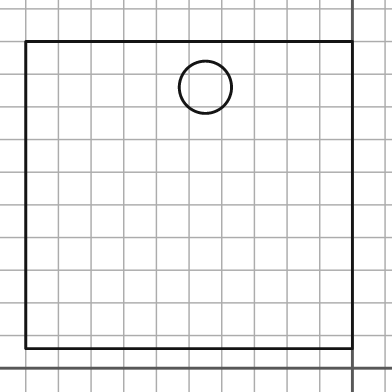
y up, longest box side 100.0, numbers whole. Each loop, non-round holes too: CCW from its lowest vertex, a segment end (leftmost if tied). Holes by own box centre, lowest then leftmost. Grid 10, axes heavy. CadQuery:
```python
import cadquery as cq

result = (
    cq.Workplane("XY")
    .moveTo(-100.0, 6.0)
    .lineTo(0.0, 6.0)
    .lineTo(0.0, 100.0)
    .lineTo(-100.0, 100.0)
    .close()
    .moveTo(-45.0, 86.0)
    .circle(8.0)
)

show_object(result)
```